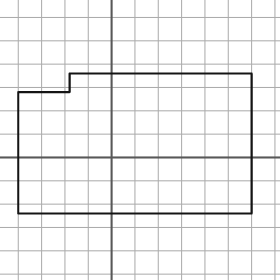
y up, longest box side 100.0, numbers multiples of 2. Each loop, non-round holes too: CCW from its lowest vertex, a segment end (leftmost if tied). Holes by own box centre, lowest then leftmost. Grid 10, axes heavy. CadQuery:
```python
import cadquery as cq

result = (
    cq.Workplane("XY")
    .moveTo(-40.0, -24.0)
    .lineTo(60.0, -24.0)
    .lineTo(60.0, 36.0)
    .lineTo(-18.0, 36.0)
    .lineTo(-18.0, 28.0)
    .lineTo(-40.0, 28.0)
    .close()
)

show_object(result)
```